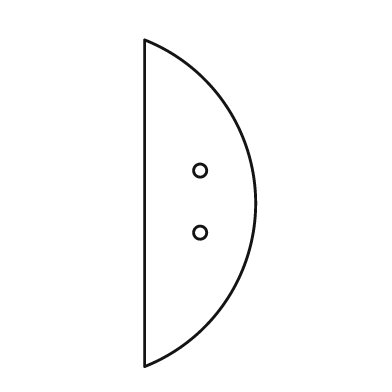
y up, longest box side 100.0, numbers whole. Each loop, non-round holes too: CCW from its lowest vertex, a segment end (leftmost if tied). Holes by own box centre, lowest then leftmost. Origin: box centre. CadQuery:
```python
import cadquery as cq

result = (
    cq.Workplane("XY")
    .moveTo(-17.0, -50.0)
    .threePointArc((17.0, 0.0), (-17.0, 50.0))
    .close()
    .moveTo(0.0, -9.0)
    .circle(2.0)
    .moveTo(0.0, 10.0)
    .circle(2.0)
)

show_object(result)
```